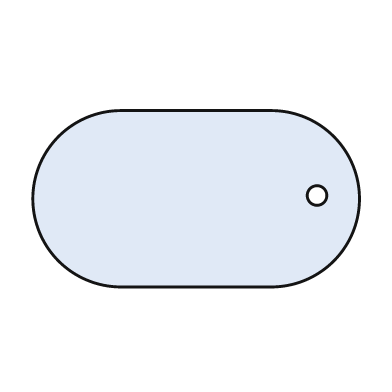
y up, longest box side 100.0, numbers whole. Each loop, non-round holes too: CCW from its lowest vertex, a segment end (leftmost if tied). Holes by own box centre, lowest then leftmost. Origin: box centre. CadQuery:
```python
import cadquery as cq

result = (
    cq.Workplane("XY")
    .moveTo(-23.0, -27.0)
    .lineTo(23.0, -27.0)
    .threePointArc((50.0, 0.0), (23.0, 27.0))
    .lineTo(-23.0, 27.0)
    .threePointArc((-50.0, 0.0), (-23.0, -27.0))
    .close()
    .moveTo(37.0, 1.0)
    .circle(3.0)
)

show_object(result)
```